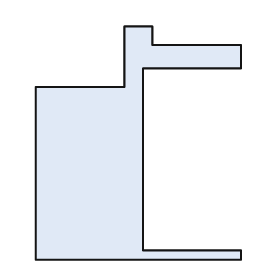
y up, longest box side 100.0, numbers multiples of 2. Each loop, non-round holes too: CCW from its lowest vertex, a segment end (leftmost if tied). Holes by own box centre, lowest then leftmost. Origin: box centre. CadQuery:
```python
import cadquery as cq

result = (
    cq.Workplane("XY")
    .moveTo(-44.0, -50.0)
    .lineTo(44.0, -50.0)
    .lineTo(44.0, -46.0)
    .lineTo(2.0, -46.0)
    .lineTo(2.0, 32.0)
    .lineTo(44.0, 32.0)
    .lineTo(44.0, 42.0)
    .lineTo(6.0, 42.0)
    .lineTo(6.0, 50.0)
    .lineTo(-6.0, 50.0)
    .lineTo(-6.0, 24.0)
    .lineTo(-44.0, 24.0)
    .close()
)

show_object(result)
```